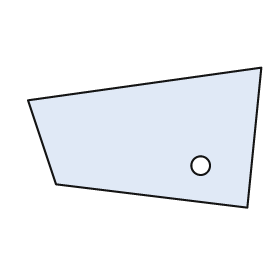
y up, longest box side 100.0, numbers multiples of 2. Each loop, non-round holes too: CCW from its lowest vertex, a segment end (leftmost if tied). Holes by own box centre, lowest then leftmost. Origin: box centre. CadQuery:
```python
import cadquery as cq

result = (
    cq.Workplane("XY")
    .moveTo(44.0, -30.0)
    .lineTo(50.0, 30.0)
    .lineTo(-50.0, 16.0)
    .lineTo(-38.0, -20.0)
    .close()
    .moveTo(24.0, -12.0)
    .circle(4.0)
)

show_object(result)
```